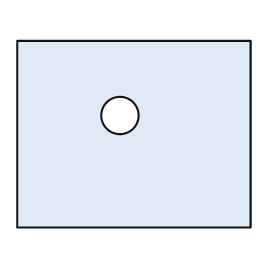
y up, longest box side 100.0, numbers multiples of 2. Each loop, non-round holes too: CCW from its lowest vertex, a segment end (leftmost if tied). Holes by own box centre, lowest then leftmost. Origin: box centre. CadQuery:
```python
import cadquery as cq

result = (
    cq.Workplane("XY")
    .moveTo(-50.0, -40.0)
    .lineTo(50.0, -40.0)
    .lineTo(50.0, 40.0)
    .lineTo(-50.0, 40.0)
    .close()
    .moveTo(-6.0, 8.0)
    .circle(8.0)
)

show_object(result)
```